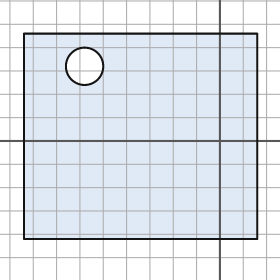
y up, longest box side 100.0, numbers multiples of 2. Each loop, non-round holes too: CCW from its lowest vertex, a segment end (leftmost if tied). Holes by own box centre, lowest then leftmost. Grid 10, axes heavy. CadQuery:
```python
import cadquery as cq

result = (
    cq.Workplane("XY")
    .moveTo(-84.0, -42.0)
    .lineTo(16.0, -42.0)
    .lineTo(16.0, 46.0)
    .lineTo(-84.0, 46.0)
    .close()
    .moveTo(-58.0, 32.0)
    .circle(8.0)
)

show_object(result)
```